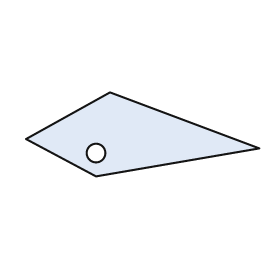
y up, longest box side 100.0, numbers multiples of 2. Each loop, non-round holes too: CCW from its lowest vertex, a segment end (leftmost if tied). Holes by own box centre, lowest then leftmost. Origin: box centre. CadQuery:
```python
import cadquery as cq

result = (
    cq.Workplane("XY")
    .moveTo(-20.0, -18.0)
    .lineTo(50.0, -6.0)
    .lineTo(-14.0, 18.0)
    .lineTo(-50.0, -2.0)
    .close()
    .moveTo(-20.0, -8.0)
    .circle(4.0)
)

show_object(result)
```